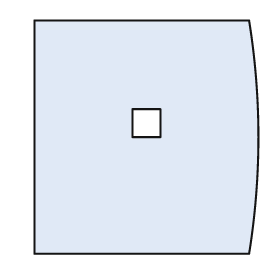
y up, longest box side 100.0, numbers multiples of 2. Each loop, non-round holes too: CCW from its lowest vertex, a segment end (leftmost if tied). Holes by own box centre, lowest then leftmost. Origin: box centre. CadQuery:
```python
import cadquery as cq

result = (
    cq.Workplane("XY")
    .moveTo(-48.0, -50.0)
    .lineTo(44.0, -50.0)
    .threePointArc((48.0, 0.0), (44.0, 50.0))
    .lineTo(-48.0, 50.0)
    .close()
    .moveTo(-6.0, 0.0)
    .lineTo(6.0, 0.0)
    .lineTo(6.0, 12.0)
    .lineTo(-6.0, 12.0)
    .close()
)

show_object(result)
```